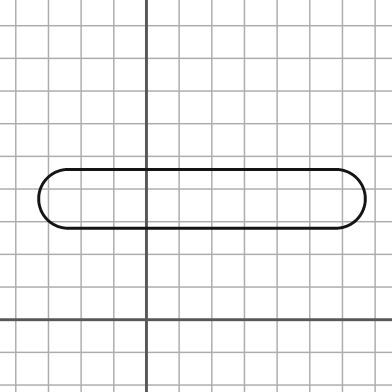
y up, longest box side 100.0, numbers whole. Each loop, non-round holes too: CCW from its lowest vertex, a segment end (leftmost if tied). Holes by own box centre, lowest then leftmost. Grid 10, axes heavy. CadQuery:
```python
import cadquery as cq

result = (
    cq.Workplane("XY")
    .moveTo(-24.0, 28.0)
    .lineTo(58.0, 28.0)
    .threePointArc((67.0, 37.0), (58.0, 46.0))
    .lineTo(-24.0, 46.0)
    .threePointArc((-33.0, 37.0), (-24.0, 28.0))
    .close()
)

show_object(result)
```